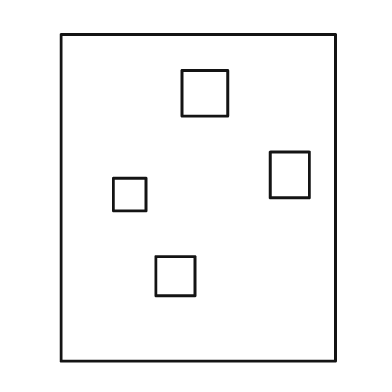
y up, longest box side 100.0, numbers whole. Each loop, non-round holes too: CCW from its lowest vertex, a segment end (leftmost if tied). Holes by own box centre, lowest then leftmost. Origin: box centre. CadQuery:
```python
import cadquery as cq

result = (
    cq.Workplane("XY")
    .moveTo(-42.0, -50.0)
    .lineTo(42.0, -50.0)
    .lineTo(42.0, 50.0)
    .lineTo(-42.0, 50.0)
    .close()
    .moveTo(-13.0, -30.0)
    .lineTo(-1.0, -30.0)
    .lineTo(-1.0, -18.0)
    .lineTo(-13.0, -18.0)
    .close()
    .moveTo(-26.0, -4.0)
    .lineTo(-16.0, -4.0)
    .lineTo(-16.0, 6.0)
    .lineTo(-26.0, 6.0)
    .close()
    .moveTo(22.0, 0.0)
    .lineTo(34.0, 0.0)
    .lineTo(34.0, 14.0)
    .lineTo(22.0, 14.0)
    .close()
    .moveTo(-5.0, 25.0)
    .lineTo(9.0, 25.0)
    .lineTo(9.0, 39.0)
    .lineTo(-5.0, 39.0)
    .close()
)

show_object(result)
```